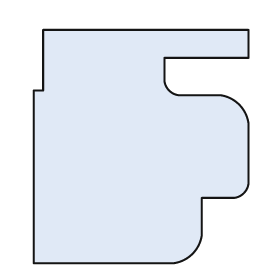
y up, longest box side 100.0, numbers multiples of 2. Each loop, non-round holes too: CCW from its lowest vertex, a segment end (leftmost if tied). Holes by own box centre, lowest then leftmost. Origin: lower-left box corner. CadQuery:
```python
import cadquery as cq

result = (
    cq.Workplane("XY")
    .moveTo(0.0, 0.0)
    .lineTo(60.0, 0.0)
    .threePointArc((68.0, 4.0), (72.0, 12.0))
    .lineTo(72.0, 28.0)
    .lineTo(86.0, 28.0)
    .threePointArc((90.0, 30.0), (92.0, 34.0))
    .lineTo(92.0, 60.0)
    .threePointArc((88.0, 68.0), (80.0, 72.0))
    .lineTo(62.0, 72.0)
    .threePointArc((58.0, 74.0), (56.0, 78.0))
    .lineTo(56.0, 88.0)
    .lineTo(92.0, 88.0)
    .lineTo(92.0, 100.0)
    .lineTo(4.0, 100.0)
    .lineTo(4.0, 74.0)
    .lineTo(0.0, 74.0)
    .close()
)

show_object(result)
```